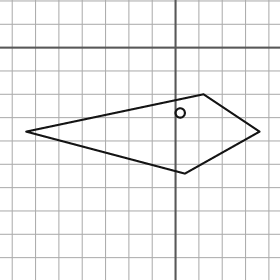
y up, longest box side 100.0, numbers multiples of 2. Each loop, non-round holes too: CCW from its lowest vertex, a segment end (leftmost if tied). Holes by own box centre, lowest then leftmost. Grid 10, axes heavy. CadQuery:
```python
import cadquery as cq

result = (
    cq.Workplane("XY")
    .moveTo(4.0, -54.0)
    .lineTo(36.0, -36.0)
    .lineTo(12.0, -20.0)
    .lineTo(-64.0, -36.0)
    .close()
    .moveTo(2.0, -28.0)
    .circle(2.0)
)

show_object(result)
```